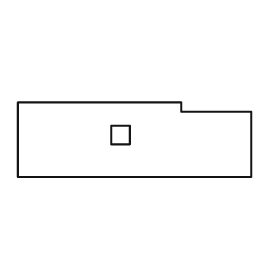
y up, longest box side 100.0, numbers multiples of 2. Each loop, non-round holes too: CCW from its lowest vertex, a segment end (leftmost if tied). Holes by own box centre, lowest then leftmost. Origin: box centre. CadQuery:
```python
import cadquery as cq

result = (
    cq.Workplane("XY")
    .moveTo(-50.0, -16.0)
    .lineTo(50.0, -16.0)
    .lineTo(50.0, 12.0)
    .lineTo(20.0, 12.0)
    .lineTo(20.0, 16.0)
    .lineTo(-50.0, 16.0)
    .close()
    .moveTo(-10.0, -2.0)
    .lineTo(-2.0, -2.0)
    .lineTo(-2.0, 6.0)
    .lineTo(-10.0, 6.0)
    .close()
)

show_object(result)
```